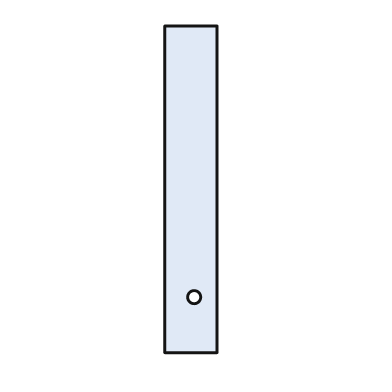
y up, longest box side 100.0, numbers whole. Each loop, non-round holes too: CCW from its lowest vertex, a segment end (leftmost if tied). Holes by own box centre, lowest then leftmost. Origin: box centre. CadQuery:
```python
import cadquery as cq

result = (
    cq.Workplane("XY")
    .moveTo(-8.0, -50.0)
    .lineTo(8.0, -50.0)
    .lineTo(8.0, 50.0)
    .lineTo(-8.0, 50.0)
    .close()
    .moveTo(1.0, -33.0)
    .circle(2.0)
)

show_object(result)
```